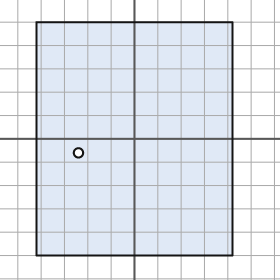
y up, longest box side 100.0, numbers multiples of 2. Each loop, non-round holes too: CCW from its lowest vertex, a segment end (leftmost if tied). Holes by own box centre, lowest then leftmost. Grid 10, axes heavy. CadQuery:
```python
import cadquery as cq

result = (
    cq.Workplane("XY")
    .moveTo(-42.0, -50.0)
    .lineTo(42.0, -50.0)
    .lineTo(42.0, 50.0)
    .lineTo(-42.0, 50.0)
    .close()
    .moveTo(-24.0, -6.0)
    .circle(2.0)
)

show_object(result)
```